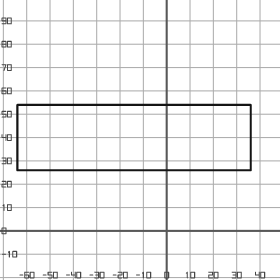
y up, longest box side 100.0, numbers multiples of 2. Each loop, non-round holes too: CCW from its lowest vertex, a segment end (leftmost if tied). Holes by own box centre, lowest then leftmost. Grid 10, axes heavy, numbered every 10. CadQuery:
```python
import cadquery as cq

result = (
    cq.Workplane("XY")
    .moveTo(-64.0, 26.0)
    .lineTo(36.0, 26.0)
    .lineTo(36.0, 54.0)
    .lineTo(-64.0, 54.0)
    .close()
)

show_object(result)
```